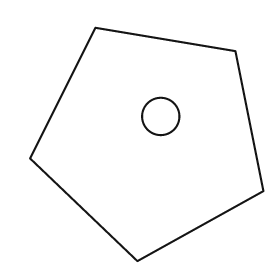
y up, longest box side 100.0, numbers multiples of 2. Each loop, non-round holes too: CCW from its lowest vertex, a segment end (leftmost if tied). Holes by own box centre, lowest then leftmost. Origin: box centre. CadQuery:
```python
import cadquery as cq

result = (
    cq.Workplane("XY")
    .moveTo(-4.0, -50.0)
    .lineTo(50.0, -20.0)
    .lineTo(38.0, 40.0)
    .lineTo(-22.0, 50.0)
    .lineTo(-50.0, -6.0)
    .close()
    .moveTo(6.0, 12.0)
    .circle(8.0)
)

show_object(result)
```